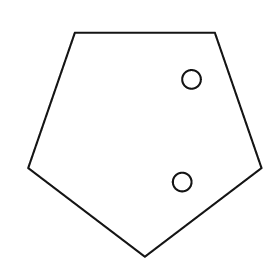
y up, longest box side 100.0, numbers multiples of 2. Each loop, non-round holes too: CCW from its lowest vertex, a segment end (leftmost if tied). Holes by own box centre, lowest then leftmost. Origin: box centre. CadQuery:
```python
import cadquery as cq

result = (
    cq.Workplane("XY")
    .moveTo(0.0, -48.0)
    .lineTo(50.0, -10.0)
    .lineTo(30.0, 48.0)
    .lineTo(-30.0, 48.0)
    .lineTo(-50.0, -10.0)
    .close()
    .moveTo(16.0, -16.0)
    .circle(4.0)
    .moveTo(20.0, 28.0)
    .circle(4.0)
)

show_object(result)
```